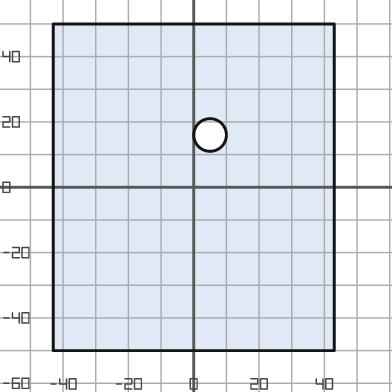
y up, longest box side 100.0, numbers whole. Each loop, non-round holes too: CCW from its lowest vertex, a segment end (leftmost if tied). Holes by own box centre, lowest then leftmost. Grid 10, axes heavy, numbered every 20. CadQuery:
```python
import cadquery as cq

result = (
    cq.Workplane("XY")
    .moveTo(-43.0, -50.0)
    .lineTo(43.0, -50.0)
    .lineTo(43.0, 50.0)
    .lineTo(-43.0, 50.0)
    .close()
    .moveTo(5.0, 16.0)
    .circle(5.0)
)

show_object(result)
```